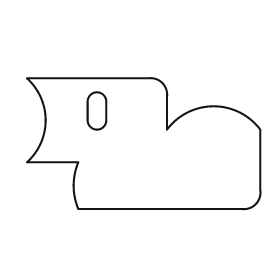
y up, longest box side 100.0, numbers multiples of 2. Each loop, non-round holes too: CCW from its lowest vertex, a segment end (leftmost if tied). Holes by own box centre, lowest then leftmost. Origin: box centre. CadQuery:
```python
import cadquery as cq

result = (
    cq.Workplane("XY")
    .moveTo(-28.0, -28.0)
    .lineTo(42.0, -28.0)
    .threePointArc((48.0, -26.0), (50.0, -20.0))
    .lineTo(50.0, 6.0)
    .threePointArc((30.0, 16.0), (10.0, 6.0))
    .lineTo(10.0, 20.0)
    .threePointArc((8.0, 26.0), (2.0, 28.0))
    .lineTo(-50.0, 28.0)
    .threePointArc((-42.0, 10.0), (-50.0, -8.0))
    .lineTo(-28.0, -8.0)
    .threePointArc((-30.0, -18.0), (-28.0, -28.0))
    .close()
    .moveTo(-24.0, 10.0)
    .threePointArc((-20.0, 6.0), (-16.0, 10.0))
    .lineTo(-16.0, 18.0)
    .threePointArc((-20.0, 22.0), (-24.0, 18.0))
    .close()
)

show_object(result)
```